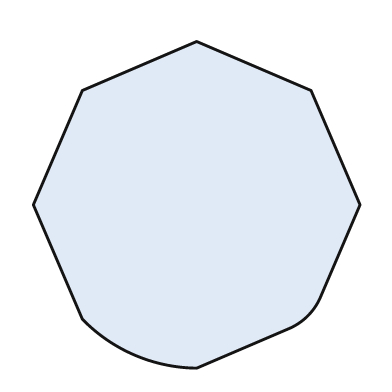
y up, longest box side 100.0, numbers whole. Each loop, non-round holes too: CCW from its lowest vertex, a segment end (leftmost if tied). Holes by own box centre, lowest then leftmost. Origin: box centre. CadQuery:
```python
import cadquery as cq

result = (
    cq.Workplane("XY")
    .moveTo(0.0, -50.0)
    .lineTo(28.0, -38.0)
    .threePointArc((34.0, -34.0), (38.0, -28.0))
    .lineTo(50.0, 0.0)
    .lineTo(35.0, 35.0)
    .lineTo(0.0, 50.0)
    .lineTo(-35.0, 35.0)
    .lineTo(-50.0, 0.0)
    .lineTo(-35.0, -35.0)
    .threePointArc((-19.0, -46.0), (0.0, -50.0))
    .close()
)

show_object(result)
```